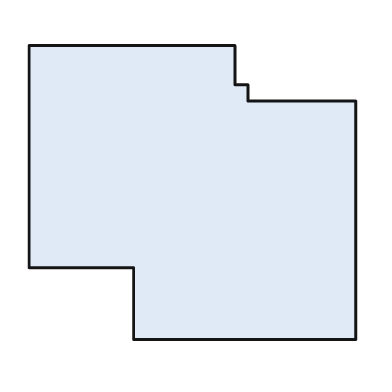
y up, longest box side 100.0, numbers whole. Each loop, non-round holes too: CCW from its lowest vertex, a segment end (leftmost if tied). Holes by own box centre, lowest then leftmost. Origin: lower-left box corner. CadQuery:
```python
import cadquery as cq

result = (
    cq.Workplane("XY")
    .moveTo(32.0, 0.0)
    .lineTo(100.0, 0.0)
    .lineTo(100.0, 73.0)
    .lineTo(67.0, 73.0)
    .lineTo(67.0, 78.0)
    .lineTo(63.0, 78.0)
    .lineTo(63.0, 90.0)
    .lineTo(0.0, 90.0)
    .lineTo(0.0, 22.0)
    .lineTo(32.0, 22.0)
    .close()
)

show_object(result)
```